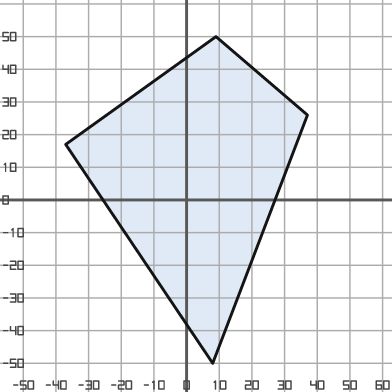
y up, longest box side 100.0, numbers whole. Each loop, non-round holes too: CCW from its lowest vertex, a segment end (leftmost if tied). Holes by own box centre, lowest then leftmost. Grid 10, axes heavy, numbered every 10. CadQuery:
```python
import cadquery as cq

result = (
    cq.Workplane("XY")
    .moveTo(8.0, -50.0)
    .lineTo(37.0, 26.0)
    .lineTo(9.0, 50.0)
    .lineTo(-37.0, 17.0)
    .close()
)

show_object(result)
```